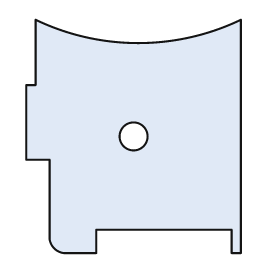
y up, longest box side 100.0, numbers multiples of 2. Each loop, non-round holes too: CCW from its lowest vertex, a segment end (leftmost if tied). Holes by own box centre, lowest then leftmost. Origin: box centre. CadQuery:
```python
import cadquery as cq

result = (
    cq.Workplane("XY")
    .moveTo(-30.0, -50.0)
    .lineTo(-16.0, -50.0)
    .lineTo(-16.0, -40.0)
    .lineTo(42.0, -40.0)
    .lineTo(42.0, -50.0)
    .lineTo(46.0, -50.0)
    .lineTo(46.0, 50.0)
    .threePointArc((2.0, 40.0), (-42.0, 50.0))
    .lineTo(-42.0, 22.0)
    .lineTo(-46.0, 22.0)
    .lineTo(-46.0, -10.0)
    .lineTo(-36.0, -10.0)
    .lineTo(-36.0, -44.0)
    .threePointArc((-34.0, -48.0), (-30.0, -50.0))
    .close()
    .moveTo(0.0, 0.0)
    .circle(6.0)
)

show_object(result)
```